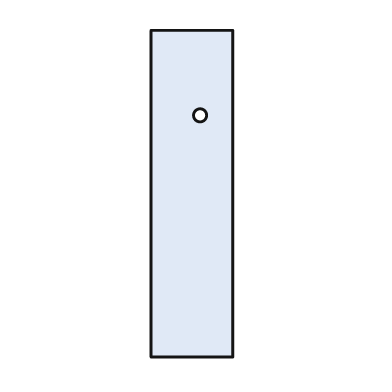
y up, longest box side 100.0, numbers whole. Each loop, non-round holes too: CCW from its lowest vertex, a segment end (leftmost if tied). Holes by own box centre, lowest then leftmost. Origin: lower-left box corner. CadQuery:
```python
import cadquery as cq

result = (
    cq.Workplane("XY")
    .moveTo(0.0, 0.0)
    .lineTo(25.0, 0.0)
    .lineTo(25.0, 100.0)
    .lineTo(0.0, 100.0)
    .close()
    .moveTo(15.0, 74.0)
    .circle(2.0)
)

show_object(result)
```